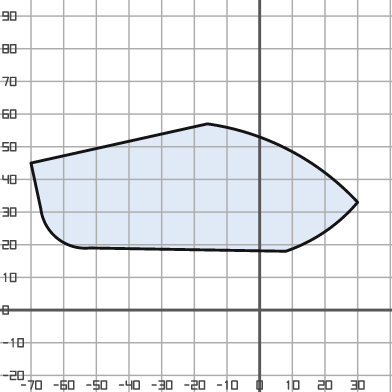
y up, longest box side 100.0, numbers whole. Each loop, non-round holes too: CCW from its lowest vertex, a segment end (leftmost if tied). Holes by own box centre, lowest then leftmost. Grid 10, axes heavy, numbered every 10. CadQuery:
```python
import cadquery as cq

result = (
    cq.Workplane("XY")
    .moveTo(8.0, 18.0)
    .threePointArc((20.0, 24.0), (30.0, 33.0))
    .threePointArc((9.0, 49.0), (-16.0, 57.0))
    .lineTo(-70.0, 45.0)
    .lineTo(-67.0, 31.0)
    .threePointArc((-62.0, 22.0), (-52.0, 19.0))
    .close()
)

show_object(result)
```